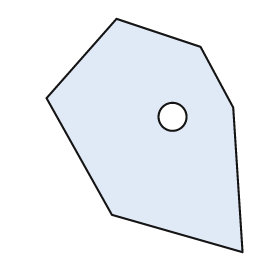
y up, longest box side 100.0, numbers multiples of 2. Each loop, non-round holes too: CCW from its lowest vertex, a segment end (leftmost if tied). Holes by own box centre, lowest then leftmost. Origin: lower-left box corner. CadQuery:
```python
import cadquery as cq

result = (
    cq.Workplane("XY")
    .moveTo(84.0, 0.0)
    .lineTo(80.0, 62.0)
    .lineTo(66.0, 88.0)
    .lineTo(30.0, 100.0)
    .lineTo(0.0, 66.0)
    .lineTo(28.0, 16.0)
    .close()
    .moveTo(54.0, 58.0)
    .circle(6.0)
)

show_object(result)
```